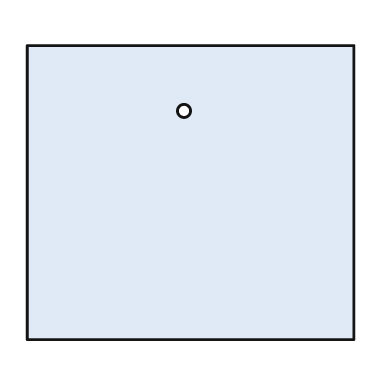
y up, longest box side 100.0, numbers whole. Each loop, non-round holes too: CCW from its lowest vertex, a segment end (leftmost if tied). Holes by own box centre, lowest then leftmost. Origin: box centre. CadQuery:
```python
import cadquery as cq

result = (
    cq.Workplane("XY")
    .moveTo(-50.0, -45.0)
    .lineTo(50.0, -45.0)
    .lineTo(50.0, 45.0)
    .lineTo(-50.0, 45.0)
    .close()
    .moveTo(-2.0, 25.0)
    .circle(2.0)
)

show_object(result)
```